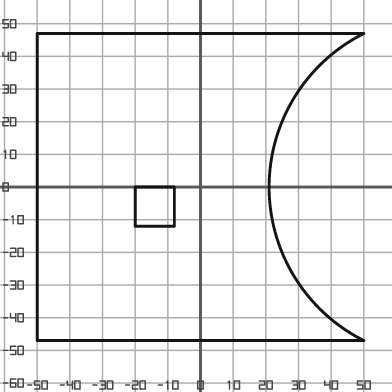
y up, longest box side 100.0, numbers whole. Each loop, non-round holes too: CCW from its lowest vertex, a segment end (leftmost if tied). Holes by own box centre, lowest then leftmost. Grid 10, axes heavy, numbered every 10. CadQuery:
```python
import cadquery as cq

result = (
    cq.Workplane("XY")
    .moveTo(-50.0, -47.0)
    .lineTo(50.0, -47.0)
    .threePointArc((21.0, 0.0), (50.0, 47.0))
    .lineTo(-50.0, 47.0)
    .close()
    .moveTo(-20.0, -12.0)
    .lineTo(-8.0, -12.0)
    .lineTo(-8.0, 0.0)
    .lineTo(-20.0, 0.0)
    .close()
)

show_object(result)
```